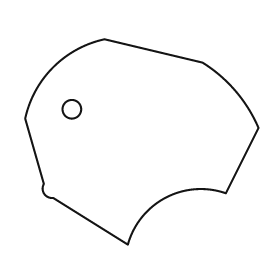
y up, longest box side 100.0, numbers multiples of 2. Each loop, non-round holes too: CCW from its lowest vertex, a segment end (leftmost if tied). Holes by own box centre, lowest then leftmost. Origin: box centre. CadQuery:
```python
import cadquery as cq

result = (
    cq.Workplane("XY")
    .moveTo(-6.0, -44.0)
    .threePointArc((10.0, -24.0), (36.0, -22.0))
    .lineTo(50.0, 6.0)
    .threePointArc((40.0, 22.0), (26.0, 34.0))
    .lineTo(-16.0, 44.0)
    .threePointArc((-38.0, 32.0), (-50.0, 10.0))
    .lineTo(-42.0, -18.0)
    .threePointArc((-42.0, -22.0), (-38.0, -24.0))
    .close()
    .moveTo(-30.0, 14.0)
    .circle(4.0)
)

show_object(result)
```